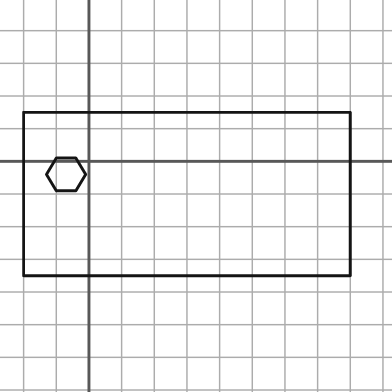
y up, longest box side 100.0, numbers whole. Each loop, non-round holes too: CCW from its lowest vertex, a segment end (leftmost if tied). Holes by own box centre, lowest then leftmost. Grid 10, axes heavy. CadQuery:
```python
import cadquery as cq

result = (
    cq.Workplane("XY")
    .moveTo(-20.0, -35.0)
    .lineTo(80.0, -35.0)
    .lineTo(80.0, 15.0)
    .lineTo(-20.0, 15.0)
    .close()
    .moveTo(-10.0, -9.0)
    .lineTo(-4.0, -9.0)
    .lineTo(-1.0, -4.0)
    .lineTo(-4.0, 1.0)
    .lineTo(-10.0, 1.0)
    .lineTo(-13.0, -4.0)
    .close()
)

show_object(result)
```